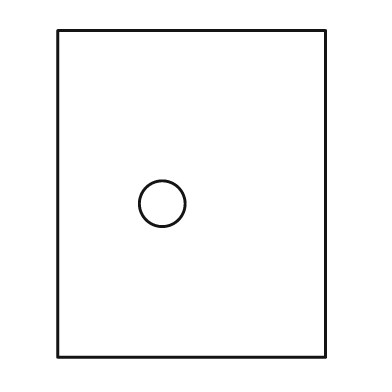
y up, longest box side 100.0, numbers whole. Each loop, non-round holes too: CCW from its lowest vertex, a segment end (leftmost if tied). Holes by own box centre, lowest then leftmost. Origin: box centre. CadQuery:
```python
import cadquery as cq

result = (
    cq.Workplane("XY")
    .moveTo(-41.0, -50.0)
    .lineTo(41.0, -50.0)
    .lineTo(41.0, 50.0)
    .lineTo(-41.0, 50.0)
    .close()
    .moveTo(-9.0, -3.0)
    .circle(7.0)
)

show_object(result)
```